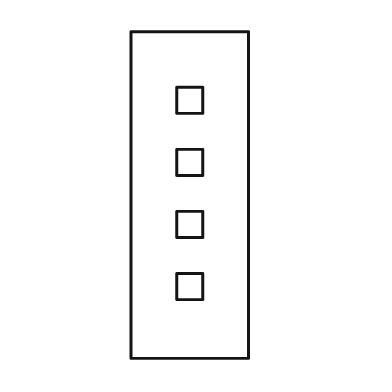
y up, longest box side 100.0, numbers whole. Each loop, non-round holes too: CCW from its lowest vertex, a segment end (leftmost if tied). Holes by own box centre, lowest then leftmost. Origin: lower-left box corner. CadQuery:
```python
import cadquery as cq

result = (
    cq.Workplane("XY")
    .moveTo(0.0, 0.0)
    .lineTo(36.0, 0.0)
    .lineTo(36.0, 100.0)
    .lineTo(0.0, 100.0)
    .close()
    .moveTo(14.0, 18.0)
    .lineTo(22.0, 18.0)
    .lineTo(22.0, 26.0)
    .lineTo(14.0, 26.0)
    .close()
    .moveTo(14.0, 37.0)
    .lineTo(22.0, 37.0)
    .lineTo(22.0, 45.0)
    .lineTo(14.0, 45.0)
    .close()
    .moveTo(14.0, 56.0)
    .lineTo(22.0, 56.0)
    .lineTo(22.0, 64.0)
    .lineTo(14.0, 64.0)
    .close()
    .moveTo(14.0, 75.0)
    .lineTo(22.0, 75.0)
    .lineTo(22.0, 83.0)
    .lineTo(14.0, 83.0)
    .close()
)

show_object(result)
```